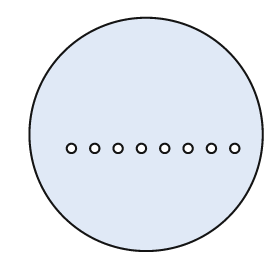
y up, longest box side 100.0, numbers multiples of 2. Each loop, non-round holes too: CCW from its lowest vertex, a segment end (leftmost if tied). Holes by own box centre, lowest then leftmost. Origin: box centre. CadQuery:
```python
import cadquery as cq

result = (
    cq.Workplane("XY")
    .moveTo(0.0, 0.0)
    .circle(50.0)
    .moveTo(-32.0, -6.0)
    .circle(2.0)
    .moveTo(-22.0, -6.0)
    .circle(2.0)
    .moveTo(-12.0, -6.0)
    .circle(2.0)
    .moveTo(-2.0, -6.0)
    .circle(2.0)
    .moveTo(8.0, -6.0)
    .circle(2.0)
    .moveTo(18.0, -6.0)
    .circle(2.0)
    .moveTo(28.0, -6.0)
    .circle(2.0)
    .moveTo(38.0, -6.0)
    .circle(2.0)
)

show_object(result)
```